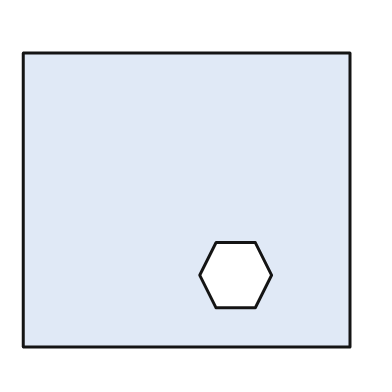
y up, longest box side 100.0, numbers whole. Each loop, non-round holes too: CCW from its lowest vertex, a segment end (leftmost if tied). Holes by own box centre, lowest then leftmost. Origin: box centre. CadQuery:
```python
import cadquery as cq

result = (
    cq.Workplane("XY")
    .moveTo(-50.0, -45.0)
    .lineTo(50.0, -45.0)
    .lineTo(50.0, 45.0)
    .lineTo(-50.0, 45.0)
    .close()
    .moveTo(9.0, -33.0)
    .lineTo(21.0, -33.0)
    .lineTo(26.0, -23.0)
    .lineTo(21.0, -13.0)
    .lineTo(9.0, -13.0)
    .lineTo(4.0, -23.0)
    .close()
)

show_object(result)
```